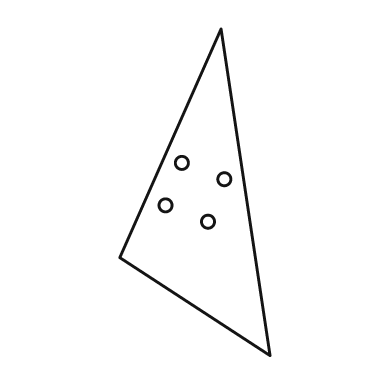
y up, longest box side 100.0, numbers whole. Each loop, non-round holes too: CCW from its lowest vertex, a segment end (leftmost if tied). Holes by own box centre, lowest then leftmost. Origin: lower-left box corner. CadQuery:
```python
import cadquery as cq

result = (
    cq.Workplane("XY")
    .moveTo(46.0, 0.0)
    .lineTo(31.0, 100.0)
    .lineTo(0.0, 30.0)
    .close()
    .moveTo(27.0, 41.0)
    .circle(2.0)
    .moveTo(14.0, 46.0)
    .circle(2.0)
    .moveTo(32.0, 54.0)
    .circle(2.0)
    .moveTo(19.0, 59.0)
    .circle(2.0)
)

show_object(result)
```